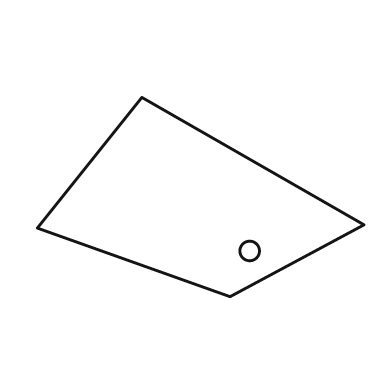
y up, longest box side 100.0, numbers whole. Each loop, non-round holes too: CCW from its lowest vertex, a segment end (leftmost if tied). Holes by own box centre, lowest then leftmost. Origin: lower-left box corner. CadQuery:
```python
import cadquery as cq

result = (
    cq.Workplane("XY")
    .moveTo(59.0, 0.0)
    .lineTo(100.0, 22.0)
    .lineTo(32.0, 61.0)
    .lineTo(0.0, 21.0)
    .close()
    .moveTo(65.0, 14.0)
    .circle(3.0)
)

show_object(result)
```